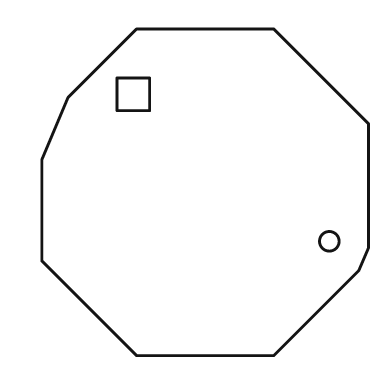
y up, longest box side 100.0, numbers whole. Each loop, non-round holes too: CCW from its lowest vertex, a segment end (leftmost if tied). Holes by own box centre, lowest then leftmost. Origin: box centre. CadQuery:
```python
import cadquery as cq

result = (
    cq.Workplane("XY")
    .moveTo(-21.0, -50.0)
    .lineTo(21.0, -50.0)
    .lineTo(47.0, -24.0)
    .lineTo(50.0, -17.0)
    .lineTo(50.0, 21.0)
    .lineTo(21.0, 50.0)
    .lineTo(-21.0, 50.0)
    .lineTo(-42.0, 29.0)
    .lineTo(-50.0, 10.0)
    .lineTo(-50.0, -21.0)
    .close()
    .moveTo(38.0, -15.0)
    .circle(3.0)
    .moveTo(-27.0, 25.0)
    .lineTo(-17.0, 25.0)
    .lineTo(-17.0, 35.0)
    .lineTo(-27.0, 35.0)
    .close()
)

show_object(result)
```